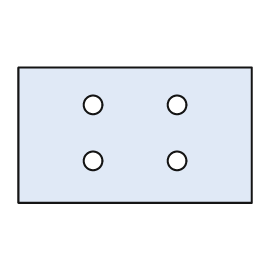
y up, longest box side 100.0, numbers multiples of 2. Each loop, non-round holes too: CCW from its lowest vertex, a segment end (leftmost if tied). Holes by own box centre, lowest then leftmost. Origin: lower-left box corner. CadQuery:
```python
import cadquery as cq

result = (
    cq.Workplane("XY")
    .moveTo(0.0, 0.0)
    .lineTo(100.0, 0.0)
    .lineTo(100.0, 58.0)
    .lineTo(0.0, 58.0)
    .close()
    .moveTo(32.0, 18.0)
    .circle(4.0)
    .moveTo(68.0, 18.0)
    .circle(4.0)
    .moveTo(32.0, 42.0)
    .circle(4.0)
    .moveTo(68.0, 42.0)
    .circle(4.0)
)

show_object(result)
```